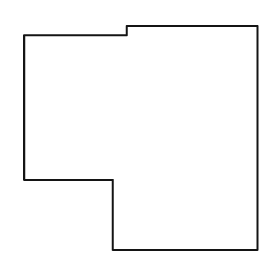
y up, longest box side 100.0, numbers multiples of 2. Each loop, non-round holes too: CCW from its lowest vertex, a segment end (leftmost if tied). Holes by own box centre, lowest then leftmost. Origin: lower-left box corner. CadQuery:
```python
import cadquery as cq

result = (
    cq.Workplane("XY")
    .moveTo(38.0, 0.0)
    .lineTo(100.0, 0.0)
    .lineTo(100.0, 96.0)
    .lineTo(44.0, 96.0)
    .lineTo(44.0, 92.0)
    .lineTo(0.0, 92.0)
    .lineTo(0.0, 30.0)
    .lineTo(38.0, 30.0)
    .close()
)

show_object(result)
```